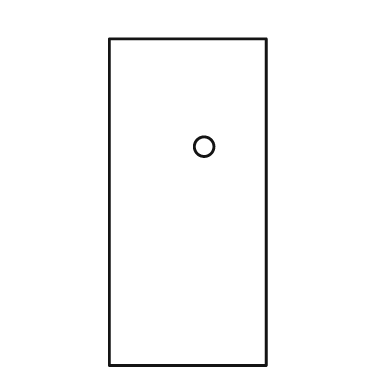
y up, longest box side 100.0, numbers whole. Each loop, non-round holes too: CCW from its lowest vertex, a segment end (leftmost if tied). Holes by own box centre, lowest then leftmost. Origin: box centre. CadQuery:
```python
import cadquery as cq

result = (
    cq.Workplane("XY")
    .moveTo(-24.0, -50.0)
    .lineTo(24.0, -50.0)
    .lineTo(24.0, 50.0)
    .lineTo(-24.0, 50.0)
    .close()
    .moveTo(5.0, 17.0)
    .circle(3.0)
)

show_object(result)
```